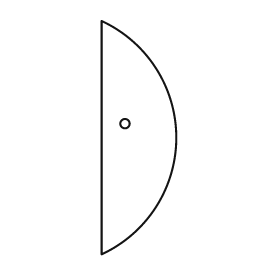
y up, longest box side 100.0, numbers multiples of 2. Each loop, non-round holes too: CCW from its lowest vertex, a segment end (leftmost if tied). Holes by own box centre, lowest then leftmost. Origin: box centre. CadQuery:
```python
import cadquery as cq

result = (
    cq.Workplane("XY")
    .moveTo(-16.0, -50.0)
    .threePointArc((16.0, 0.0), (-16.0, 50.0))
    .close()
    .moveTo(-6.0, 6.0)
    .circle(2.0)
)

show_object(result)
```